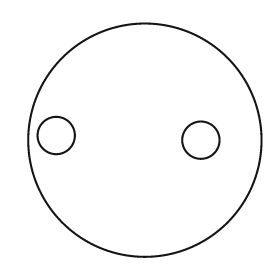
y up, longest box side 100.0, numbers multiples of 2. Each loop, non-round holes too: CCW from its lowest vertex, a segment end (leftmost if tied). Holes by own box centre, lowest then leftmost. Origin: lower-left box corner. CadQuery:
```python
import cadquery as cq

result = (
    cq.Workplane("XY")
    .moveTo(50.0, 50.0)
    .circle(50.0)
    .moveTo(74.0, 50.0)
    .circle(8.0)
    .moveTo(12.0, 52.0)
    .circle(8.0)
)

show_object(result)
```